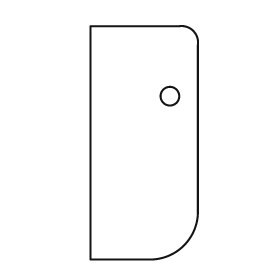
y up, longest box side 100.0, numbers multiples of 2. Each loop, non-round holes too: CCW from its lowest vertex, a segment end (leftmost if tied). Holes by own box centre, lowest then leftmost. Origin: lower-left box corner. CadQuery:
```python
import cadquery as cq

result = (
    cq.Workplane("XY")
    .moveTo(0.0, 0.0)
    .lineTo(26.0, 0.0)
    .threePointArc((40.0, 6.0), (46.0, 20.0))
    .lineTo(46.0, 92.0)
    .threePointArc((44.0, 98.0), (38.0, 100.0))
    .lineTo(0.0, 100.0)
    .close()
    .moveTo(34.0, 70.0)
    .circle(4.0)
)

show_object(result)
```